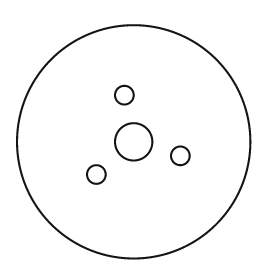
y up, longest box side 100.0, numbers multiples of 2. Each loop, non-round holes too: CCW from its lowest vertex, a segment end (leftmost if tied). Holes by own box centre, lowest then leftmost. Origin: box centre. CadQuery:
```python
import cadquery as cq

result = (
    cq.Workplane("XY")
    .moveTo(0.0, 0.0)
    .circle(50.0)
    .moveTo(-16.0, -14.0)
    .circle(4.0)
    .moveTo(20.0, -6.0)
    .circle(4.0)
    .moveTo(0.0, 0.0)
    .circle(8.0)
    .moveTo(-4.0, 20.0)
    .circle(4.0)
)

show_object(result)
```